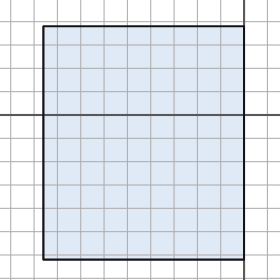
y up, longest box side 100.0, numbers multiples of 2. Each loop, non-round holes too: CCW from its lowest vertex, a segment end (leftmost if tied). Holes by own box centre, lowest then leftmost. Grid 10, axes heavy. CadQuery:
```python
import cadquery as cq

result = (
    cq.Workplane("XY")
    .moveTo(-86.0, -62.0)
    .lineTo(0.0, -62.0)
    .lineTo(0.0, 38.0)
    .lineTo(-86.0, 38.0)
    .close()
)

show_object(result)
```